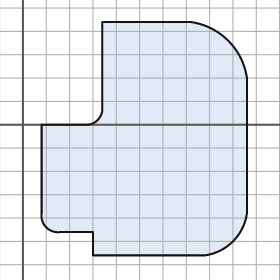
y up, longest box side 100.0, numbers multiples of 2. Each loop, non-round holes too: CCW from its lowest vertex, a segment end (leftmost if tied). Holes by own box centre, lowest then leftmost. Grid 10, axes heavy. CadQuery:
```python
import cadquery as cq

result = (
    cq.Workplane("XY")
    .moveTo(30.0, -56.0)
    .lineTo(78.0, -56.0)
    .threePointArc((90.0, -50.0), (96.0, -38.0))
    .lineTo(96.0, 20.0)
    .threePointArc((88.0, 36.0), (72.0, 44.0))
    .lineTo(34.0, 44.0)
    .lineTo(34.0, 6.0)
    .threePointArc((32.0, 2.0), (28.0, 0.0))
    .lineTo(8.0, 0.0)
    .lineTo(8.0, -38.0)
    .threePointArc((10.0, -44.0), (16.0, -46.0))
    .lineTo(30.0, -46.0)
    .close()
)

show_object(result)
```